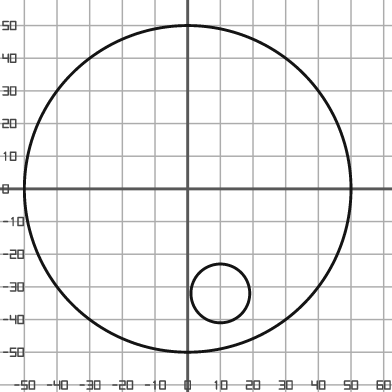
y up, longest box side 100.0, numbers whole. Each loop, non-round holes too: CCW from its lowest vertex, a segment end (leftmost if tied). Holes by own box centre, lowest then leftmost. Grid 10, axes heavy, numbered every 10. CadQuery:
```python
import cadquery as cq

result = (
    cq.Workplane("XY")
    .moveTo(0.0, 0.0)
    .circle(50.0)
    .moveTo(10.0, -32.0)
    .circle(9.0)
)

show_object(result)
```